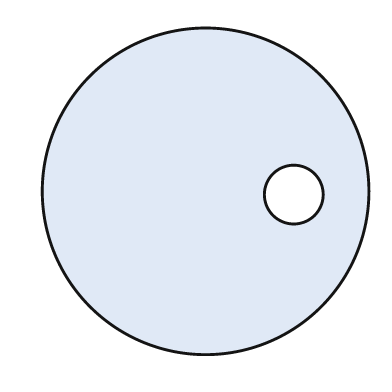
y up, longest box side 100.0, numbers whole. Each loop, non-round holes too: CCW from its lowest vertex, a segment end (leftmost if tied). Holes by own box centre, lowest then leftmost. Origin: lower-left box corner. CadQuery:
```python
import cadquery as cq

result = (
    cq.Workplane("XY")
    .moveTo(50.0, 50.0)
    .circle(50.0)
    .moveTo(77.0, 49.0)
    .circle(9.0)
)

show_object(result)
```